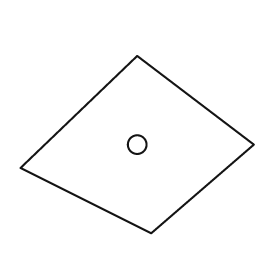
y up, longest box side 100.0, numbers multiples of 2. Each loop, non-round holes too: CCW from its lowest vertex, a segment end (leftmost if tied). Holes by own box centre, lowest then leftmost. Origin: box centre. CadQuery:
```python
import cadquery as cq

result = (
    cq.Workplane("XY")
    .moveTo(6.0, -38.0)
    .lineTo(50.0, 0.0)
    .lineTo(0.0, 38.0)
    .lineTo(-50.0, -10.0)
    .close()
    .moveTo(0.0, 0.0)
    .circle(4.0)
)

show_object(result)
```